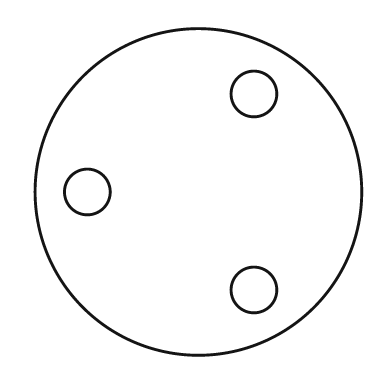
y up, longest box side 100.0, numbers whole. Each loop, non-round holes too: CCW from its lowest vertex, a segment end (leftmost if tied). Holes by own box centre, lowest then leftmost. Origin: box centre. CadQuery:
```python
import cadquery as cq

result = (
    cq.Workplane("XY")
    .moveTo(0.0, 0.0)
    .circle(50.0)
    .moveTo(17.0, -30.0)
    .circle(7.0)
    .moveTo(-34.0, 0.0)
    .circle(7.0)
    .moveTo(17.0, 30.0)
    .circle(7.0)
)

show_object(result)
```